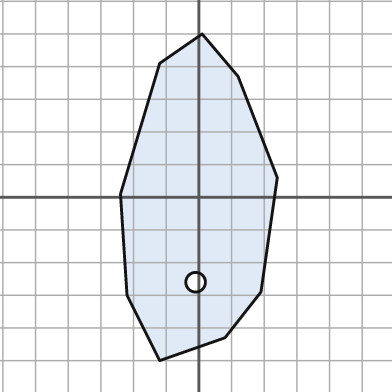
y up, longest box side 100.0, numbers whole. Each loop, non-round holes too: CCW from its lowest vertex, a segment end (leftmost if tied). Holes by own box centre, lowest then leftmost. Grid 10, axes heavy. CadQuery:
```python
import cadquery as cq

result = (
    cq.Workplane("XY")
    .moveTo(-12.0, -50.0)
    .lineTo(8.0, -43.0)
    .lineTo(19.0, -29.0)
    .lineTo(24.0, 6.0)
    .lineTo(12.0, 37.0)
    .lineTo(1.0, 50.0)
    .lineTo(-12.0, 41.0)
    .lineTo(-24.0, 1.0)
    .lineTo(-22.0, -30.0)
    .close()
    .moveTo(-1.0, -26.0)
    .circle(3.0)
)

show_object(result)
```